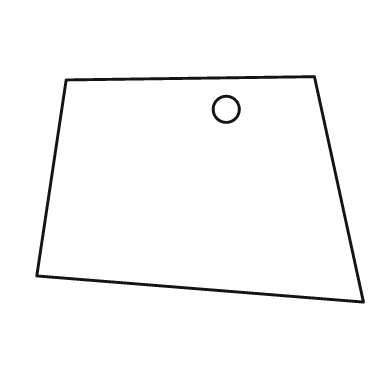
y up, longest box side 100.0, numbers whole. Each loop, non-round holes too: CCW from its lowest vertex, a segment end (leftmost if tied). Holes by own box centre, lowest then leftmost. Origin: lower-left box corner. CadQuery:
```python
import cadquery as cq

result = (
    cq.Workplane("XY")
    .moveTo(100.0, 0.0)
    .lineTo(85.0, 69.0)
    .lineTo(9.0, 68.0)
    .lineTo(0.0, 8.0)
    .close()
    .moveTo(58.0, 59.0)
    .circle(4.0)
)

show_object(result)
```